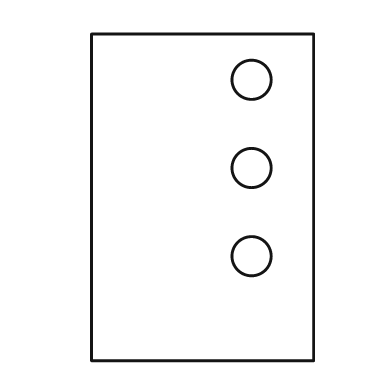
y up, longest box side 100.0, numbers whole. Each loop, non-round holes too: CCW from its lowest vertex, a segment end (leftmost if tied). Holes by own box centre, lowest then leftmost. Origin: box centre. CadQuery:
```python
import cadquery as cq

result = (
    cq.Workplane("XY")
    .moveTo(-34.0, -50.0)
    .lineTo(34.0, -50.0)
    .lineTo(34.0, 50.0)
    .lineTo(-34.0, 50.0)
    .close()
    .moveTo(15.0, -18.0)
    .circle(6.0)
    .moveTo(15.0, 9.0)
    .circle(6.0)
    .moveTo(15.0, 36.0)
    .circle(6.0)
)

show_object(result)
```